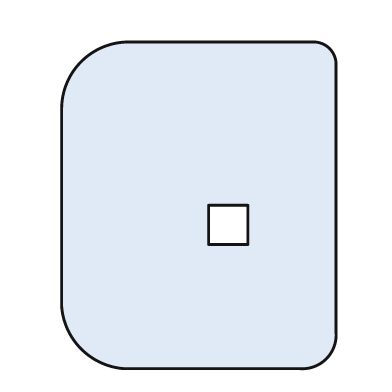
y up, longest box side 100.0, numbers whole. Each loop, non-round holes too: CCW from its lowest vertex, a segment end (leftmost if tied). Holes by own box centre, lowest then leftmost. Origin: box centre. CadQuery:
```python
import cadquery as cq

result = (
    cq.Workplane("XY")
    .moveTo(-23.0, -50.0)
    .lineTo(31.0, -50.0)
    .threePointArc((39.0, -47.0), (42.0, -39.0))
    .lineTo(42.0, 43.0)
    .threePointArc((40.0, 48.0), (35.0, 50.0))
    .lineTo(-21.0, 50.0)
    .threePointArc((-36.0, 44.0), (-42.0, 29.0))
    .lineTo(-42.0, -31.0)
    .threePointArc((-36.0, -44.0), (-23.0, -50.0))
    .close()
    .moveTo(3.0, -12.0)
    .lineTo(15.0, -12.0)
    .lineTo(15.0, 0.0)
    .lineTo(3.0, 0.0)
    .close()
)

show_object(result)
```